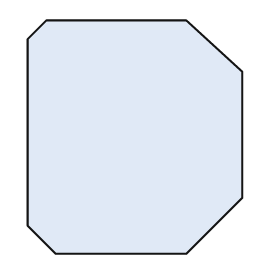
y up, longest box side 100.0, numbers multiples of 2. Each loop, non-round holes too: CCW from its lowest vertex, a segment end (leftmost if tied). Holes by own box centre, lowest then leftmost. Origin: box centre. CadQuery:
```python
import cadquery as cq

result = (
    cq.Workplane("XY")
    .moveTo(-34.0, -50.0)
    .lineTo(22.0, -50.0)
    .lineTo(46.0, -26.0)
    .lineTo(46.0, 28.0)
    .lineTo(22.0, 50.0)
    .lineTo(-38.0, 50.0)
    .lineTo(-46.0, 42.0)
    .lineTo(-46.0, -38.0)
    .close()
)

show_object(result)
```